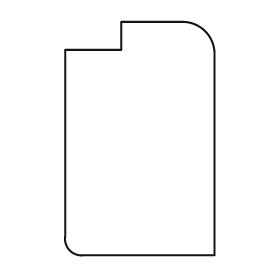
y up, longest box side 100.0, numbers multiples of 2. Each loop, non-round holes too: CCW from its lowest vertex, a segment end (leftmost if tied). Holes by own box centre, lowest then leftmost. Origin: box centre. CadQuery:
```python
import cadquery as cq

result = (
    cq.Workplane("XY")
    .moveTo(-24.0, -50.0)
    .lineTo(32.0, -50.0)
    .lineTo(32.0, 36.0)
    .threePointArc((28.0, 46.0), (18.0, 50.0))
    .lineTo(-8.0, 50.0)
    .lineTo(-8.0, 38.0)
    .lineTo(-32.0, 38.0)
    .lineTo(-32.0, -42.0)
    .threePointArc((-30.0, -48.0), (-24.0, -50.0))
    .close()
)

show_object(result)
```